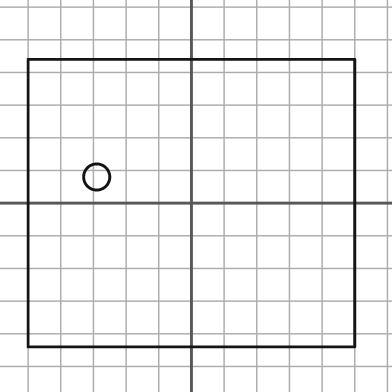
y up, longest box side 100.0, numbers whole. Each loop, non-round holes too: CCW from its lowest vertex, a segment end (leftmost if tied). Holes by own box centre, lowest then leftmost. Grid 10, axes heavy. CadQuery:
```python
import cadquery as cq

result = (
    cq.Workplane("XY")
    .moveTo(-50.0, -44.0)
    .lineTo(50.0, -44.0)
    .lineTo(50.0, 44.0)
    .lineTo(-50.0, 44.0)
    .close()
    .moveTo(-29.0, 8.0)
    .circle(4.0)
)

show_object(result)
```